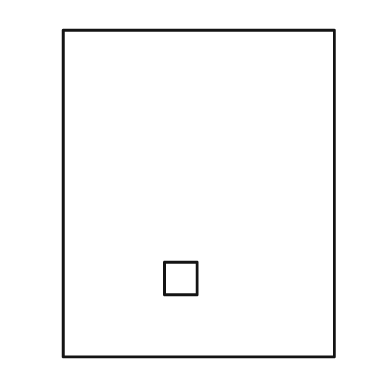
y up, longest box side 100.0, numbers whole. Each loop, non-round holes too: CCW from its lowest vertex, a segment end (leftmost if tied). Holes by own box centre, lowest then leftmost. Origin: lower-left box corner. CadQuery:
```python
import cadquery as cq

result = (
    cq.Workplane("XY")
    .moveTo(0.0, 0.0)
    .lineTo(83.0, 0.0)
    .lineTo(83.0, 100.0)
    .lineTo(0.0, 100.0)
    .close()
    .moveTo(31.0, 19.0)
    .lineTo(41.0, 19.0)
    .lineTo(41.0, 29.0)
    .lineTo(31.0, 29.0)
    .close()
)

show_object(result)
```